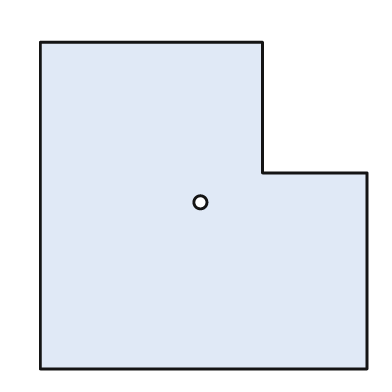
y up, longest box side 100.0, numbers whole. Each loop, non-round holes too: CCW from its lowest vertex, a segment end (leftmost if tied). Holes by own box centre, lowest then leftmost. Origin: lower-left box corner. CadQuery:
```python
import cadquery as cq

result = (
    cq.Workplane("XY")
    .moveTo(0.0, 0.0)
    .lineTo(100.0, 0.0)
    .lineTo(100.0, 60.0)
    .lineTo(68.0, 60.0)
    .lineTo(68.0, 100.0)
    .lineTo(0.0, 100.0)
    .close()
    .moveTo(49.0, 51.0)
    .circle(2.0)
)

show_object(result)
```